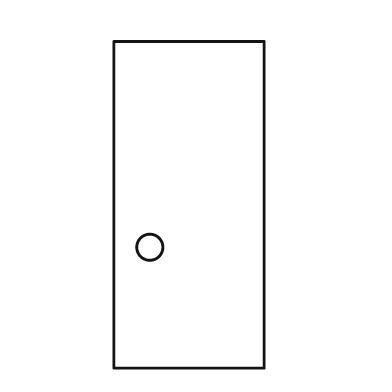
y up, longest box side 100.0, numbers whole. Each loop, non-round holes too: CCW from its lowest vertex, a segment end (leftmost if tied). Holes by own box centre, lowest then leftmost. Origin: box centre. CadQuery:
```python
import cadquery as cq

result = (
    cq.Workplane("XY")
    .moveTo(-23.0, -50.0)
    .lineTo(23.0, -50.0)
    .lineTo(23.0, 50.0)
    .lineTo(-23.0, 50.0)
    .close()
    .moveTo(-12.0, -13.0)
    .circle(4.0)
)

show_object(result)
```